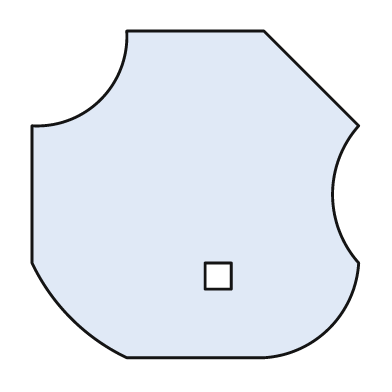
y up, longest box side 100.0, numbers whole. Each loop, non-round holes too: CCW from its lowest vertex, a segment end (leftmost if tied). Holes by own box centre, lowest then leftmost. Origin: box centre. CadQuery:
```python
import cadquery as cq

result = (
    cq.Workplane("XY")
    .moveTo(-21.0, -50.0)
    .lineTo(21.0, -50.0)
    .threePointArc((41.0, -41.0), (50.0, -21.0))
    .threePointArc((42.0, 0.0), (50.0, 21.0))
    .lineTo(21.0, 50.0)
    .lineTo(-21.0, 50.0)
    .threePointArc((-29.0, 29.0), (-50.0, 21.0))
    .lineTo(-50.0, -21.0)
    .threePointArc((-38.0, -38.0), (-21.0, -50.0))
    .close()
    .moveTo(3.0, -29.0)
    .lineTo(11.0, -29.0)
    .lineTo(11.0, -21.0)
    .lineTo(3.0, -21.0)
    .close()
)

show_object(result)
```